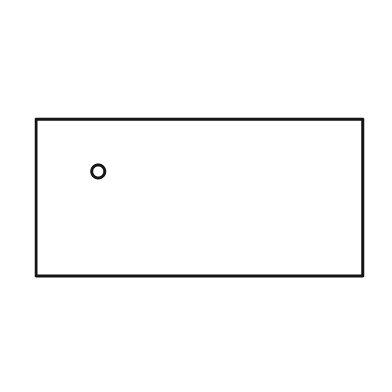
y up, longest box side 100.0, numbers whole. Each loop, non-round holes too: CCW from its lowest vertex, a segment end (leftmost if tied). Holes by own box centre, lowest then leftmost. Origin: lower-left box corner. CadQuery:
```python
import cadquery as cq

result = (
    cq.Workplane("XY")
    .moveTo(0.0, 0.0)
    .lineTo(100.0, 0.0)
    .lineTo(100.0, 48.0)
    .lineTo(0.0, 48.0)
    .close()
    .moveTo(19.0, 32.0)
    .circle(2.0)
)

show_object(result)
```